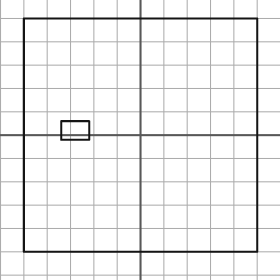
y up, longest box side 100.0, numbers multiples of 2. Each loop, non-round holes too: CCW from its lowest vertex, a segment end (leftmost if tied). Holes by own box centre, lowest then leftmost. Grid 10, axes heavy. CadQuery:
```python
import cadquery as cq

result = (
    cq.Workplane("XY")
    .moveTo(-50.0, -50.0)
    .lineTo(50.0, -50.0)
    .lineTo(50.0, 50.0)
    .lineTo(-50.0, 50.0)
    .close()
    .moveTo(-34.0, -2.0)
    .lineTo(-22.0, -2.0)
    .lineTo(-22.0, 6.0)
    .lineTo(-34.0, 6.0)
    .close()
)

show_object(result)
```